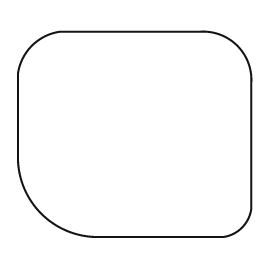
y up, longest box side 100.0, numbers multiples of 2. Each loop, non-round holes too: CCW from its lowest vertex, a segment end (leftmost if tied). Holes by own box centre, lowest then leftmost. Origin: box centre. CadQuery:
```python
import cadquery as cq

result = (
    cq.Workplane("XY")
    .moveTo(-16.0, -44.0)
    .lineTo(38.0, -44.0)
    .threePointArc((46.0, -40.0), (50.0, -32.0))
    .lineTo(50.0, 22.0)
    .threePointArc((44.0, 38.0), (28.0, 44.0))
    .lineTo(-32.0, 44.0)
    .threePointArc((-44.0, 38.0), (-50.0, 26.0))
    .lineTo(-50.0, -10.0)
    .threePointArc((-40.0, -34.0), (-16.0, -44.0))
    .close()
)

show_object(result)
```